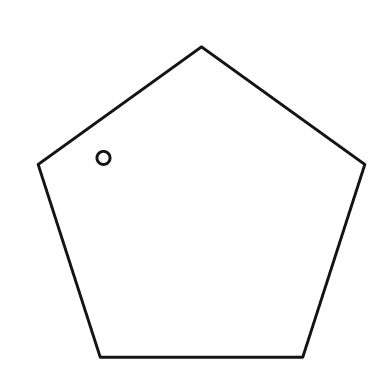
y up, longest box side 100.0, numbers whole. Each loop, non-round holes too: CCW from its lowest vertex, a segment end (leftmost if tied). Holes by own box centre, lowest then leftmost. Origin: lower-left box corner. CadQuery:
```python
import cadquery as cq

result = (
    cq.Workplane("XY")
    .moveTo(19.0, 0.0)
    .lineTo(81.0, 0.0)
    .lineTo(100.0, 59.0)
    .lineTo(50.0, 95.0)
    .lineTo(0.0, 59.0)
    .close()
    .moveTo(20.0, 61.0)
    .circle(2.0)
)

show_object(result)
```